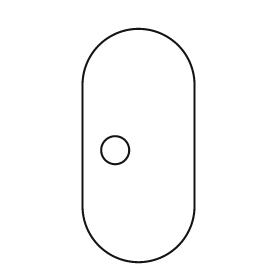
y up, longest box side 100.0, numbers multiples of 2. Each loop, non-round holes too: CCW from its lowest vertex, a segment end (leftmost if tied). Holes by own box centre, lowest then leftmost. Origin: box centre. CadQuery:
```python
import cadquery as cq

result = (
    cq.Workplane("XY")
    .moveTo(-24.0, -26.0)
    .threePointArc((0.0, -50.0), (24.0, -26.0))
    .lineTo(24.0, 26.0)
    .threePointArc((0.0, 50.0), (-24.0, 26.0))
    .close()
    .moveTo(-10.0, -2.0)
    .circle(6.0)
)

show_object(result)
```